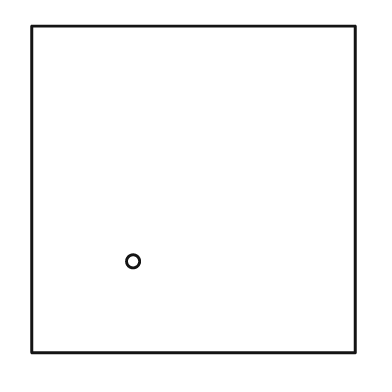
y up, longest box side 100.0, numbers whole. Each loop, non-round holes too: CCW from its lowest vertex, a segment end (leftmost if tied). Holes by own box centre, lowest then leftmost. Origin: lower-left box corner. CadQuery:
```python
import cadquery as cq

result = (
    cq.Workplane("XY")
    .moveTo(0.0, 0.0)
    .lineTo(99.0, 0.0)
    .lineTo(99.0, 100.0)
    .lineTo(0.0, 100.0)
    .close()
    .moveTo(31.0, 28.0)
    .circle(2.0)
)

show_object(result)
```